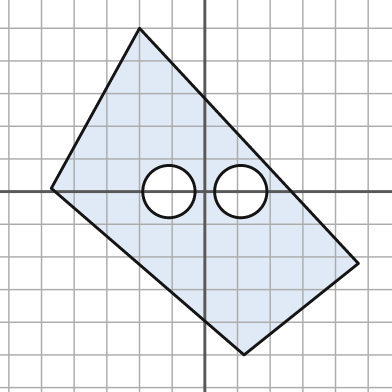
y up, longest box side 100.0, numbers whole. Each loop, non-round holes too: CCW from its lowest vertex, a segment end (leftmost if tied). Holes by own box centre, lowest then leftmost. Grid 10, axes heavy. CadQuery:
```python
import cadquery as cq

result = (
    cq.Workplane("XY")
    .moveTo(12.0, -50.0)
    .lineTo(47.0, -22.0)
    .lineTo(-20.0, 50.0)
    .lineTo(-47.0, 1.0)
    .close()
    .moveTo(-11.0, 0.0)
    .circle(8.0)
    .moveTo(11.0, 0.0)
    .circle(8.0)
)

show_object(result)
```